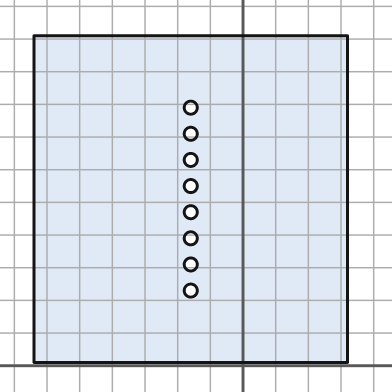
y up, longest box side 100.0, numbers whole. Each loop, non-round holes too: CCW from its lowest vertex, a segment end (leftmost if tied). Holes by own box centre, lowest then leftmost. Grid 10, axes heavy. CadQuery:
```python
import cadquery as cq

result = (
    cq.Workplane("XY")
    .moveTo(-64.0, 1.0)
    .lineTo(32.0, 1.0)
    .lineTo(32.0, 101.0)
    .lineTo(-64.0, 101.0)
    .close()
    .moveTo(-16.0, 23.0)
    .circle(2.0)
    .moveTo(-16.0, 31.0)
    .circle(2.0)
    .moveTo(-16.0, 39.0)
    .circle(2.0)
    .moveTo(-16.0, 47.0)
    .circle(2.0)
    .moveTo(-16.0, 55.0)
    .circle(2.0)
    .moveTo(-16.0, 63.0)
    .circle(2.0)
    .moveTo(-16.0, 71.0)
    .circle(2.0)
    .moveTo(-16.0, 79.0)
    .circle(2.0)
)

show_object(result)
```